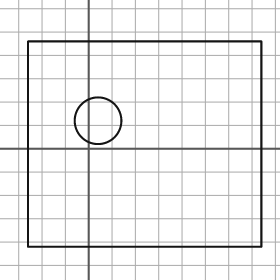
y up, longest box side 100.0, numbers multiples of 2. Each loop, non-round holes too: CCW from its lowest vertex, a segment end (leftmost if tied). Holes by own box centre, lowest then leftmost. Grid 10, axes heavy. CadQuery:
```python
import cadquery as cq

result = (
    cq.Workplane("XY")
    .moveTo(-26.0, -42.0)
    .lineTo(74.0, -42.0)
    .lineTo(74.0, 46.0)
    .lineTo(-26.0, 46.0)
    .close()
    .moveTo(4.0, 12.0)
    .circle(10.0)
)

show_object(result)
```